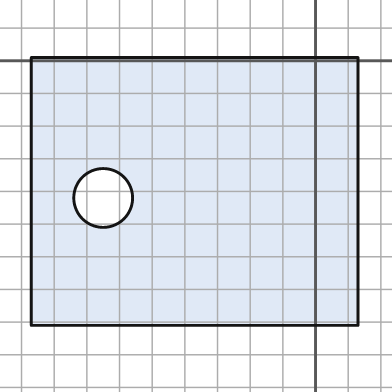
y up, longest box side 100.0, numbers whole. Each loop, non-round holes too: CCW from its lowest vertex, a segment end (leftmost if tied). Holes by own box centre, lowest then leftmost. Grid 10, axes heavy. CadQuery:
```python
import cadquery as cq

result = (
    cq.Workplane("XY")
    .moveTo(-87.0, -81.0)
    .lineTo(13.0, -81.0)
    .lineTo(13.0, 1.0)
    .lineTo(-87.0, 1.0)
    .close()
    .moveTo(-65.0, -42.0)
    .circle(9.0)
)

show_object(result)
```